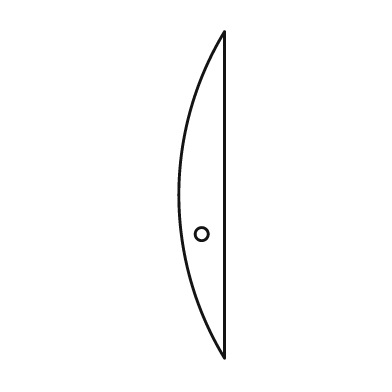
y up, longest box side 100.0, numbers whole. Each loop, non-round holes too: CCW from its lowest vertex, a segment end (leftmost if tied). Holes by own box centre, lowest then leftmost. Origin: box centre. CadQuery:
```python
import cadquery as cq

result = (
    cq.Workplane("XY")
    .moveTo(7.0, -50.0)
    .lineTo(7.0, 50.0)
    .threePointArc((-7.0, 0.0), (7.0, -50.0))
    .close()
    .moveTo(0.0, -12.0)
    .circle(2.0)
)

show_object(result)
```